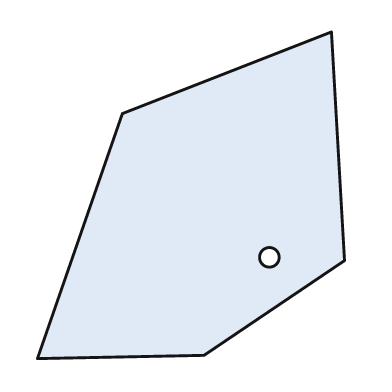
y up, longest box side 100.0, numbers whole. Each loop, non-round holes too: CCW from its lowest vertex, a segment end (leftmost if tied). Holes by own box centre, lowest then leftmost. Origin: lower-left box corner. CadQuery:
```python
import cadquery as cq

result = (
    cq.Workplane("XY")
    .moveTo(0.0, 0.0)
    .lineTo(51.0, 1.0)
    .lineTo(94.0, 30.0)
    .lineTo(90.0, 100.0)
    .lineTo(26.0, 75.0)
    .close()
    .moveTo(71.0, 31.0)
    .circle(3.0)
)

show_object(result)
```